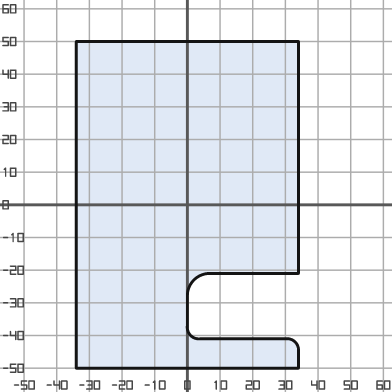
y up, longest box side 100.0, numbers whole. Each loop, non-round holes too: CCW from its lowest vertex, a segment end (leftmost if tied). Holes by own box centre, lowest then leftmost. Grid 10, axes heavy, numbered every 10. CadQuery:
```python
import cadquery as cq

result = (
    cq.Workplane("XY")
    .moveTo(-34.0, -50.0)
    .lineTo(34.0, -50.0)
    .lineTo(34.0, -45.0)
    .threePointArc((33.0, -42.0), (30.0, -41.0))
    .lineTo(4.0, -41.0)
    .threePointArc((1.0, -40.0), (0.0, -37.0))
    .lineTo(0.0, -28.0)
    .threePointArc((2.0, -23.0), (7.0, -21.0))
    .lineTo(34.0, -21.0)
    .lineTo(34.0, 50.0)
    .lineTo(-34.0, 50.0)
    .close()
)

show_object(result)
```